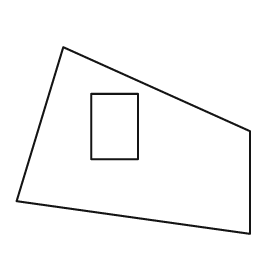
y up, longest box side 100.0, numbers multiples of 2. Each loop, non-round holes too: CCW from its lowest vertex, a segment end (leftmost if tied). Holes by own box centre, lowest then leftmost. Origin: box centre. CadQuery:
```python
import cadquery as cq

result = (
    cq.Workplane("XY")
    .moveTo(50.0, -40.0)
    .lineTo(50.0, 4.0)
    .lineTo(-30.0, 40.0)
    .lineTo(-50.0, -26.0)
    .close()
    .moveTo(-18.0, -8.0)
    .lineTo(2.0, -8.0)
    .lineTo(2.0, 20.0)
    .lineTo(-18.0, 20.0)
    .close()
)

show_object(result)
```